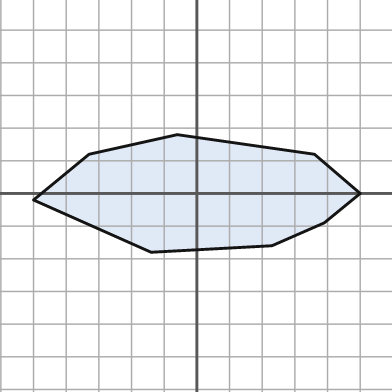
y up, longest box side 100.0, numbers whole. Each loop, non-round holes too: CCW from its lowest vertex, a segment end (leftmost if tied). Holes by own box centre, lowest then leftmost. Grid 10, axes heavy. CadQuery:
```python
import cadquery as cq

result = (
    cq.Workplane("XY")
    .moveTo(-14.0, -18.0)
    .lineTo(23.0, -16.0)
    .lineTo(39.0, -9.0)
    .lineTo(50.0, 0.0)
    .lineTo(36.0, 12.0)
    .lineTo(-6.0, 18.0)
    .lineTo(-33.0, 12.0)
    .lineTo(-50.0, -2.0)
    .close()
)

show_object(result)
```